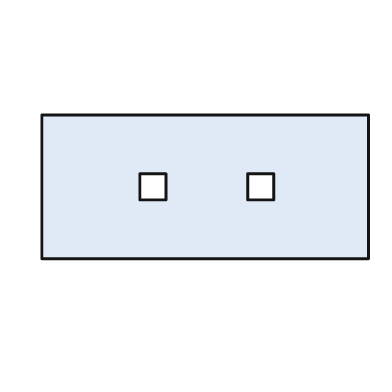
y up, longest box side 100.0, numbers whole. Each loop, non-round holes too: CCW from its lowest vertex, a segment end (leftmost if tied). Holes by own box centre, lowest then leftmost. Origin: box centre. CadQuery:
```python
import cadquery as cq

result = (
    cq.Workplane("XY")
    .moveTo(-50.0, -22.0)
    .lineTo(50.0, -22.0)
    .lineTo(50.0, 22.0)
    .lineTo(-50.0, 22.0)
    .close()
    .moveTo(-20.0, -4.0)
    .lineTo(-12.0, -4.0)
    .lineTo(-12.0, 4.0)
    .lineTo(-20.0, 4.0)
    .close()
    .moveTo(13.0, -4.0)
    .lineTo(21.0, -4.0)
    .lineTo(21.0, 4.0)
    .lineTo(13.0, 4.0)
    .close()
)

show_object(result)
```